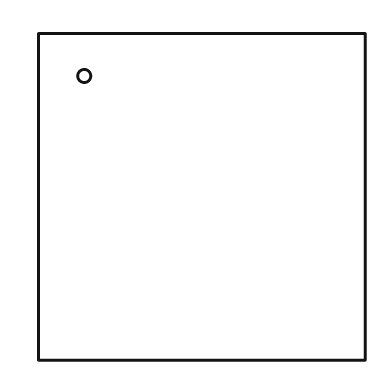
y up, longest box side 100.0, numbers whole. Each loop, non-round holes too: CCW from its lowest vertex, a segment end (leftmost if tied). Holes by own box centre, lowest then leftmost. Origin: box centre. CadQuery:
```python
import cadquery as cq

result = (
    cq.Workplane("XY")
    .moveTo(-50.0, -50.0)
    .lineTo(50.0, -50.0)
    .lineTo(50.0, 50.0)
    .lineTo(-50.0, 50.0)
    .close()
    .moveTo(-36.0, 37.0)
    .circle(2.0)
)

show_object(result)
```